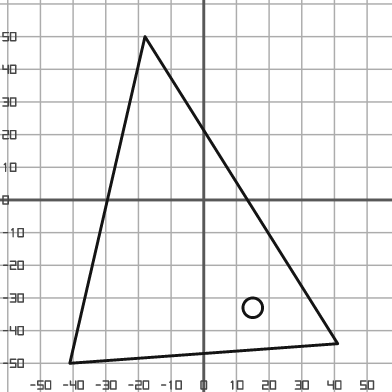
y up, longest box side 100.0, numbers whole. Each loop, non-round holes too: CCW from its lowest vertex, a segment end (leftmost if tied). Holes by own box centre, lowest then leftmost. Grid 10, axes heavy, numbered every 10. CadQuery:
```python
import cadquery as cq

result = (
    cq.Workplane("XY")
    .moveTo(-41.0, -50.0)
    .lineTo(41.0, -44.0)
    .lineTo(-18.0, 50.0)
    .close()
    .moveTo(15.0, -33.0)
    .circle(3.0)
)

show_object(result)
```